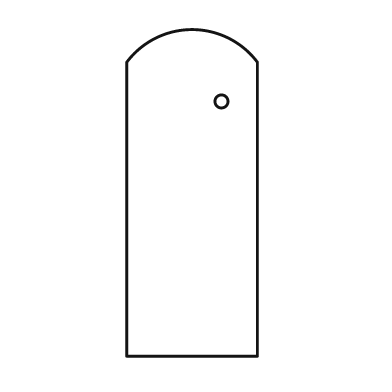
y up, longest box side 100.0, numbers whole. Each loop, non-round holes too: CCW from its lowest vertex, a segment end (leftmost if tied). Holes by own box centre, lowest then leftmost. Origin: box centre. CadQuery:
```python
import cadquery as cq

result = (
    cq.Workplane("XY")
    .moveTo(-20.0, -50.0)
    .lineTo(20.0, -50.0)
    .lineTo(20.0, 40.0)
    .threePointArc((0.0, 50.0), (-20.0, 40.0))
    .close()
    .moveTo(9.0, 28.0)
    .circle(2.0)
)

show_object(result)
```